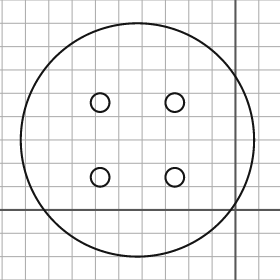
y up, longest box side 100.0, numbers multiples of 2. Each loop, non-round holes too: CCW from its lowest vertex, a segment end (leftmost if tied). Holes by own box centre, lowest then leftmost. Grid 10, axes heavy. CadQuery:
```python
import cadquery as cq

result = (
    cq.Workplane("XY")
    .moveTo(-42.0, 30.0)
    .circle(50.0)
    .moveTo(-58.0, 14.0)
    .circle(4.0)
    .moveTo(-26.0, 14.0)
    .circle(4.0)
    .moveTo(-58.0, 46.0)
    .circle(4.0)
    .moveTo(-26.0, 46.0)
    .circle(4.0)
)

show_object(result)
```